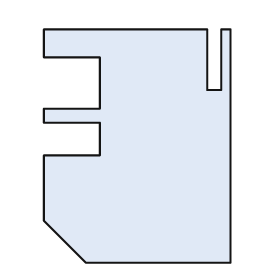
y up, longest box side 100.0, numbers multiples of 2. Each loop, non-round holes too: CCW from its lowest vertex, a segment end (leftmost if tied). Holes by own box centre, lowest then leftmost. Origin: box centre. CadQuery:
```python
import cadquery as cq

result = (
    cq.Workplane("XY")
    .moveTo(-22.0, -50.0)
    .lineTo(40.0, -50.0)
    .lineTo(40.0, 50.0)
    .lineTo(36.0, 50.0)
    .lineTo(36.0, 24.0)
    .lineTo(30.0, 24.0)
    .lineTo(30.0, 50.0)
    .lineTo(-40.0, 50.0)
    .lineTo(-40.0, 38.0)
    .lineTo(-16.0, 38.0)
    .lineTo(-16.0, 16.0)
    .lineTo(-40.0, 16.0)
    .lineTo(-40.0, 10.0)
    .lineTo(-16.0, 10.0)
    .lineTo(-16.0, -4.0)
    .lineTo(-40.0, -4.0)
    .lineTo(-40.0, -32.0)
    .close()
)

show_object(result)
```